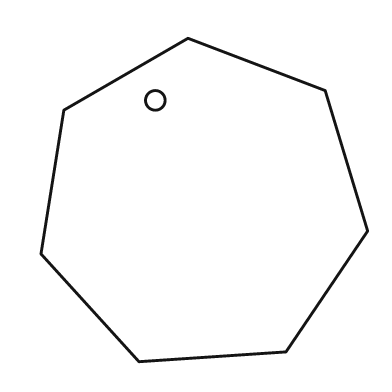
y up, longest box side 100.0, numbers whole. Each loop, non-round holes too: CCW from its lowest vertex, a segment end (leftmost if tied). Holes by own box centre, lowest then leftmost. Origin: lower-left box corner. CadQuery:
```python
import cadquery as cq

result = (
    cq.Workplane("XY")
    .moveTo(30.0, 0.0)
    .lineTo(75.0, 3.0)
    .lineTo(100.0, 40.0)
    .lineTo(87.0, 83.0)
    .lineTo(45.0, 99.0)
    .lineTo(7.0, 77.0)
    .lineTo(0.0, 33.0)
    .close()
    .moveTo(35.0, 80.0)
    .circle(3.0)
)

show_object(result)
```